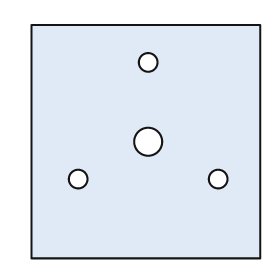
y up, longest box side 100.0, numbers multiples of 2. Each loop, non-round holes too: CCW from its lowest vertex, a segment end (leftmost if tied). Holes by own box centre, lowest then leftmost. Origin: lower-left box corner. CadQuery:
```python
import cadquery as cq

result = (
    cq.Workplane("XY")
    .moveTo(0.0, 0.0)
    .lineTo(98.0, 0.0)
    .lineTo(98.0, 100.0)
    .lineTo(0.0, 100.0)
    .close()
    .moveTo(20.0, 34.0)
    .circle(4.0)
    .moveTo(80.0, 34.0)
    .circle(4.0)
    .moveTo(50.0, 50.0)
    .circle(6.0)
    .moveTo(50.0, 84.0)
    .circle(4.0)
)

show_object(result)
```